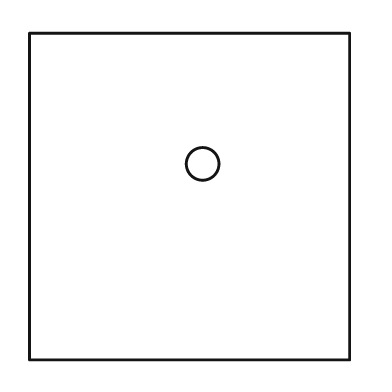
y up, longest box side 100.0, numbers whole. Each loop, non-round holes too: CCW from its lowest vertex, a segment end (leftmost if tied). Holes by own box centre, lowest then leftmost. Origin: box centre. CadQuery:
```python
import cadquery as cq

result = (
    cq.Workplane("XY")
    .moveTo(-49.0, -50.0)
    .lineTo(49.0, -50.0)
    .lineTo(49.0, 50.0)
    .lineTo(-49.0, 50.0)
    .close()
    .moveTo(4.0, 10.0)
    .circle(5.0)
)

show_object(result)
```